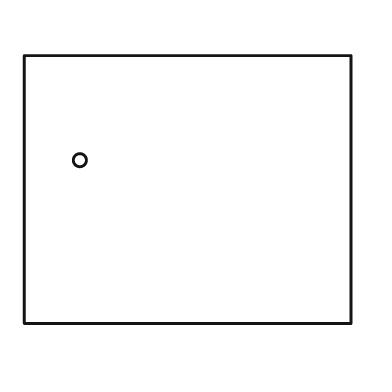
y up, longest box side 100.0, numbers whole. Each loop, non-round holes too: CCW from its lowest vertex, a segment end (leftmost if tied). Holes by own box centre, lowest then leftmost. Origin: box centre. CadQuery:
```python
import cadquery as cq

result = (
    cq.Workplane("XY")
    .moveTo(-50.0, -41.0)
    .lineTo(50.0, -41.0)
    .lineTo(50.0, 41.0)
    .lineTo(-50.0, 41.0)
    .close()
    .moveTo(-33.0, 9.0)
    .circle(2.0)
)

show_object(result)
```